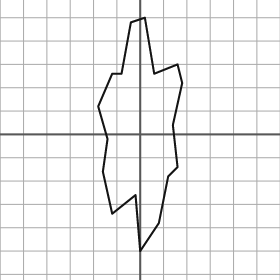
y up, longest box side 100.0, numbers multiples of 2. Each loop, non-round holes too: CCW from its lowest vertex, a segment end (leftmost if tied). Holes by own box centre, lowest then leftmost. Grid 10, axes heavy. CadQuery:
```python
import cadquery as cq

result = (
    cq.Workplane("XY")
    .moveTo(0.0, -50.0)
    .lineTo(8.0, -38.0)
    .lineTo(12.0, -18.0)
    .lineTo(16.0, -14.0)
    .lineTo(14.0, 4.0)
    .lineTo(18.0, 22.0)
    .lineTo(16.0, 30.0)
    .lineTo(6.0, 26.0)
    .lineTo(2.0, 50.0)
    .lineTo(-4.0, 48.0)
    .lineTo(-8.0, 26.0)
    .lineTo(-12.0, 26.0)
    .lineTo(-18.0, 12.0)
    .lineTo(-14.0, -2.0)
    .lineTo(-16.0, -16.0)
    .lineTo(-12.0, -34.0)
    .lineTo(-2.0, -26.0)
    .close()
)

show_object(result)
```